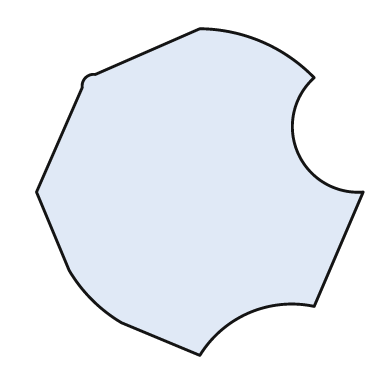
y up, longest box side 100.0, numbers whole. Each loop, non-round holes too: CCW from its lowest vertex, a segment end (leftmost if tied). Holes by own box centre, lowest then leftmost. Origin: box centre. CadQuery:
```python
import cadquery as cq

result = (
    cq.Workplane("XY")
    .moveTo(0.0, -50.0)
    .threePointArc((15.0, -37.0), (35.0, -35.0))
    .lineTo(50.0, 0.0)
    .threePointArc((30.0, 12.0), (35.0, 35.0))
    .threePointArc((19.0, 46.0), (0.0, 50.0))
    .lineTo(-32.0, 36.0)
    .threePointArc((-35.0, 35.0), (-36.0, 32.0))
    .lineTo(-50.0, 0.0)
    .lineTo(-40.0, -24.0)
    .threePointArc((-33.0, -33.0), (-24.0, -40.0))
    .close()
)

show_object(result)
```